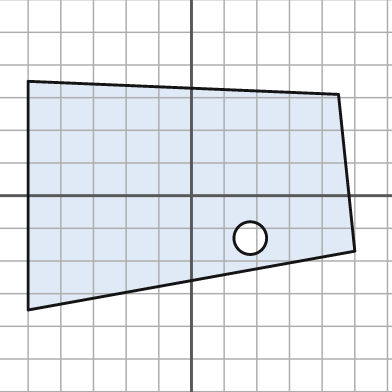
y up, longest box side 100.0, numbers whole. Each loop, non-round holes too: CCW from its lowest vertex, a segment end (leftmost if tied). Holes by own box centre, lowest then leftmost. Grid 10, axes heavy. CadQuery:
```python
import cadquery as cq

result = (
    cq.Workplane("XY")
    .moveTo(-50.0, -35.0)
    .lineTo(50.0, -17.0)
    .lineTo(45.0, 31.0)
    .lineTo(-50.0, 35.0)
    .close()
    .moveTo(18.0, -13.0)
    .circle(5.0)
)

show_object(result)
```